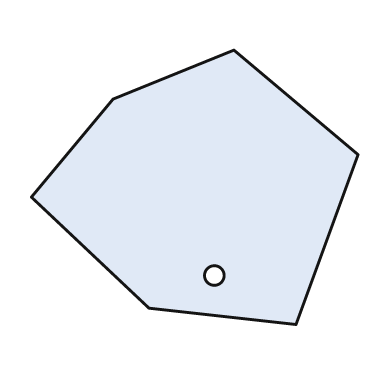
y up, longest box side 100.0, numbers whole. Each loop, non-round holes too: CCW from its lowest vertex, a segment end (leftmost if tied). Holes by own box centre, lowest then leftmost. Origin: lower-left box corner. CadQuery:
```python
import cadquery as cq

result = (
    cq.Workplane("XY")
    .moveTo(81.0, 0.0)
    .lineTo(100.0, 52.0)
    .lineTo(62.0, 84.0)
    .lineTo(25.0, 69.0)
    .lineTo(0.0, 39.0)
    .lineTo(36.0, 5.0)
    .close()
    .moveTo(56.0, 15.0)
    .circle(3.0)
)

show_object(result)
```